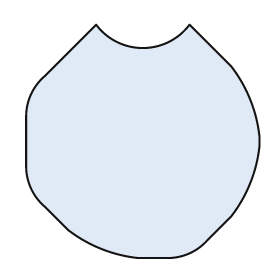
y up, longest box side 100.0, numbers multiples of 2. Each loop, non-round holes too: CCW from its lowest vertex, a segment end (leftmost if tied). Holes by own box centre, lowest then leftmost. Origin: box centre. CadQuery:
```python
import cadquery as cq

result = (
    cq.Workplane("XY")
    .moveTo(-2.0, -50.0)
    .lineTo(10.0, -50.0)
    .threePointArc((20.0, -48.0), (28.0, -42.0))
    .lineTo(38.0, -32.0)
    .threePointArc((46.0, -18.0), (50.0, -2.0))
    .lineTo(50.0, 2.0)
    .threePointArc((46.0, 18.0), (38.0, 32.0))
    .lineTo(20.0, 50.0)
    .threePointArc((0.0, 40.0), (-20.0, 50.0))
    .lineTo(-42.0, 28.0)
    .threePointArc((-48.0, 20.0), (-50.0, 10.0))
    .lineTo(-50.0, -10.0)
    .threePointArc((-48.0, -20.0), (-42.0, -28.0))
    .lineTo(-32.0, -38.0)
    .threePointArc((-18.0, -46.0), (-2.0, -50.0))
    .close()
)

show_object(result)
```